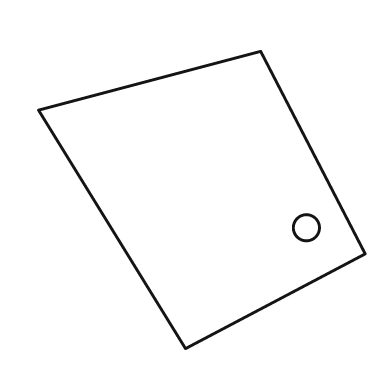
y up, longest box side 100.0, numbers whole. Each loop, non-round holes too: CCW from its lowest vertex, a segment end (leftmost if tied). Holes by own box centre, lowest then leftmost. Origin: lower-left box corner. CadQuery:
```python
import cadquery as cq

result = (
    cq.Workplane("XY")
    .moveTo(45.0, 0.0)
    .lineTo(100.0, 29.0)
    .lineTo(68.0, 91.0)
    .lineTo(0.0, 73.0)
    .close()
    .moveTo(82.0, 37.0)
    .circle(4.0)
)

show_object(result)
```